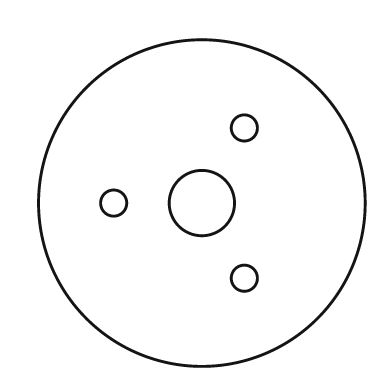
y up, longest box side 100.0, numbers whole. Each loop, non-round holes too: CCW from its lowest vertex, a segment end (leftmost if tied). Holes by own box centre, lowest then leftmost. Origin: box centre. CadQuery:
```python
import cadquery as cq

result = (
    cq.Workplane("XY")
    .moveTo(0.0, 0.0)
    .circle(50.0)
    .moveTo(13.0, -23.0)
    .circle(4.0)
    .moveTo(-27.0, 0.0)
    .circle(4.0)
    .moveTo(0.0, 0.0)
    .circle(10.0)
    .moveTo(13.0, 23.0)
    .circle(4.0)
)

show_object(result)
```